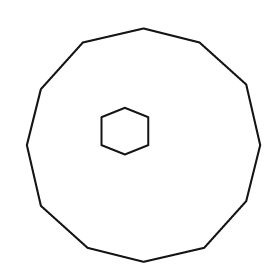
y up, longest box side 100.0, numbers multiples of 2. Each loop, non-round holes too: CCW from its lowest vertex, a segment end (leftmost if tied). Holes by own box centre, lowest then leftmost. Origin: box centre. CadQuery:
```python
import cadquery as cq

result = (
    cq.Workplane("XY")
    .moveTo(0.0, -50.0)
    .lineTo(26.0, -44.0)
    .lineTo(44.0, -24.0)
    .lineTo(50.0, 0.0)
    .lineTo(44.0, 26.0)
    .lineTo(24.0, 44.0)
    .lineTo(0.0, 50.0)
    .lineTo(-26.0, 44.0)
    .lineTo(-44.0, 24.0)
    .lineTo(-50.0, 0.0)
    .lineTo(-44.0, -26.0)
    .lineTo(-24.0, -44.0)
    .close()
    .moveTo(-8.0, -4.0)
    .lineTo(2.0, 0.0)
    .lineTo(2.0, 12.0)
    .lineTo(-8.0, 16.0)
    .lineTo(-18.0, 12.0)
    .lineTo(-18.0, 0.0)
    .close()
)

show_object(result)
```